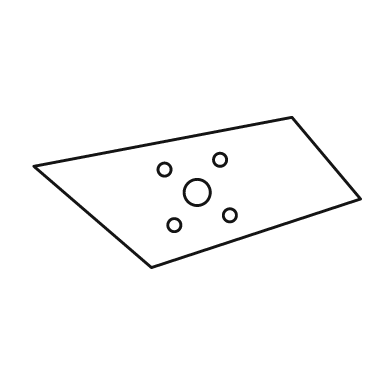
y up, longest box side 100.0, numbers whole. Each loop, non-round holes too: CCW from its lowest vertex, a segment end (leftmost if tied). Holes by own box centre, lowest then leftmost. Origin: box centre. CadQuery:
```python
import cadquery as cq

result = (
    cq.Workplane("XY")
    .moveTo(-14.0, -23.0)
    .lineTo(50.0, -2.0)
    .lineTo(29.0, 23.0)
    .lineTo(-50.0, 8.0)
    .close()
    .moveTo(-7.0, -10.0)
    .circle(2.0)
    .moveTo(10.0, -7.0)
    .circle(2.0)
    .moveTo(0.0, 0.0)
    .circle(4.0)
    .moveTo(-10.0, 7.0)
    .circle(2.0)
    .moveTo(7.0, 10.0)
    .circle(2.0)
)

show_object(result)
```